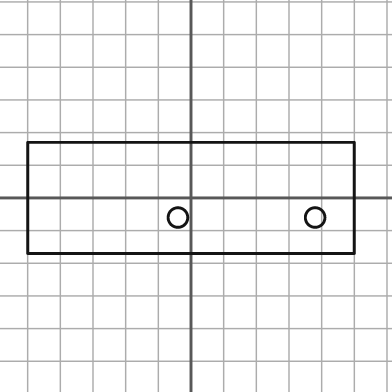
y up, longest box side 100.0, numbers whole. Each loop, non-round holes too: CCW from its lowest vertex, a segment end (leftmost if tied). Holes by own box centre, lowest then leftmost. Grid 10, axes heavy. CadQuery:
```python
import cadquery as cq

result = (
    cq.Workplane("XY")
    .moveTo(-50.0, -17.0)
    .lineTo(50.0, -17.0)
    .lineTo(50.0, 17.0)
    .lineTo(-50.0, 17.0)
    .close()
    .moveTo(-4.0, -6.0)
    .circle(3.0)
    .moveTo(38.0, -6.0)
    .circle(3.0)
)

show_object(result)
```